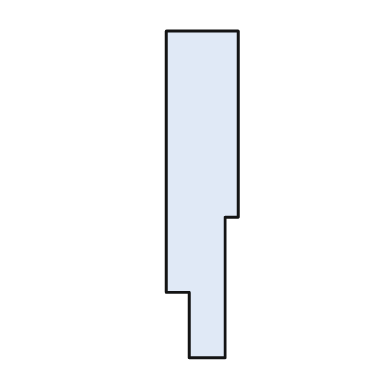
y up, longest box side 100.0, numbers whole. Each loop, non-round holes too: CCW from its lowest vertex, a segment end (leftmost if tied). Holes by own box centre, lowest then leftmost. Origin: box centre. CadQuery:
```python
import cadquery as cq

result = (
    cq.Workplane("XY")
    .moveTo(-4.0, -50.0)
    .lineTo(7.0, -50.0)
    .lineTo(7.0, -7.0)
    .lineTo(11.0, -7.0)
    .lineTo(11.0, 50.0)
    .lineTo(-11.0, 50.0)
    .lineTo(-11.0, -30.0)
    .lineTo(-4.0, -30.0)
    .close()
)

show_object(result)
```